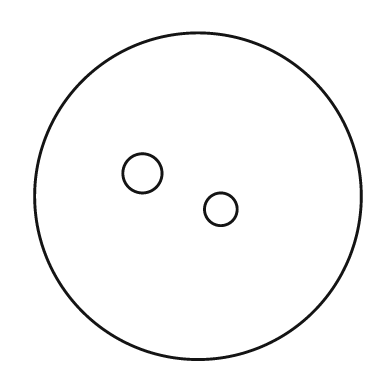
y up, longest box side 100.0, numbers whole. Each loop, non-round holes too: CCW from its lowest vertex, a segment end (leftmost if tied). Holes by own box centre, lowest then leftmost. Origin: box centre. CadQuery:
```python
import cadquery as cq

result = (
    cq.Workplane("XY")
    .moveTo(0.0, 0.0)
    .circle(50.0)
    .moveTo(7.0, -4.0)
    .circle(5.0)
    .moveTo(-17.0, 7.0)
    .circle(6.0)
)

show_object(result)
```